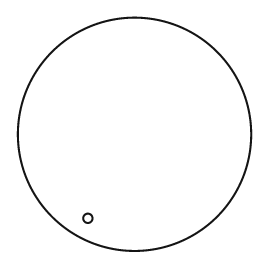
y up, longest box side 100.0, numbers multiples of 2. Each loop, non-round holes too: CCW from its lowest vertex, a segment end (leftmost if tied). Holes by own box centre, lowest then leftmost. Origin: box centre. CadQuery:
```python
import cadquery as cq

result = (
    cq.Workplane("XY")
    .moveTo(0.0, 0.0)
    .circle(50.0)
    .moveTo(-20.0, -36.0)
    .circle(2.0)
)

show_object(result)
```